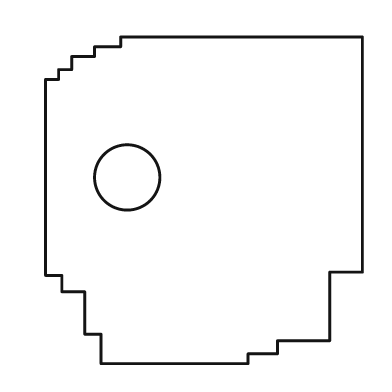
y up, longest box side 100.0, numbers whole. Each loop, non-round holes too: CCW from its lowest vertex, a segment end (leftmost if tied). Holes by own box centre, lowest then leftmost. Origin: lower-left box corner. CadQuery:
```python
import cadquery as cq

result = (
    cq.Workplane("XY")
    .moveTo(17.0, 0.0)
    .lineTo(62.0, 0.0)
    .lineTo(62.0, 3.0)
    .lineTo(71.0, 3.0)
    .lineTo(71.0, 7.0)
    .lineTo(87.0, 7.0)
    .lineTo(87.0, 28.0)
    .lineTo(97.0, 28.0)
    .lineTo(97.0, 100.0)
    .lineTo(23.0, 100.0)
    .lineTo(23.0, 97.0)
    .lineTo(15.0, 97.0)
    .lineTo(15.0, 94.0)
    .lineTo(8.0, 94.0)
    .lineTo(8.0, 90.0)
    .lineTo(4.0, 90.0)
    .lineTo(4.0, 87.0)
    .lineTo(0.0, 87.0)
    .lineTo(0.0, 27.0)
    .lineTo(5.0, 27.0)
    .lineTo(5.0, 22.0)
    .lineTo(12.0, 22.0)
    .lineTo(12.0, 9.0)
    .lineTo(17.0, 9.0)
    .close()
    .moveTo(25.0, 57.0)
    .circle(10.0)
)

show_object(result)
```